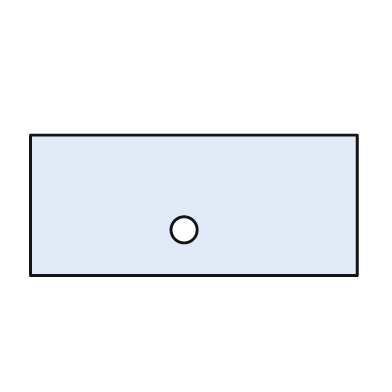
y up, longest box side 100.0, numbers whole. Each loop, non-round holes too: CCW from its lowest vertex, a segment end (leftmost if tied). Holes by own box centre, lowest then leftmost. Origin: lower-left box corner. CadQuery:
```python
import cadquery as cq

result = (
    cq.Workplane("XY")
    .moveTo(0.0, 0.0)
    .lineTo(100.0, 0.0)
    .lineTo(100.0, 43.0)
    .lineTo(0.0, 43.0)
    .close()
    .moveTo(47.0, 14.0)
    .circle(4.0)
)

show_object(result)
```